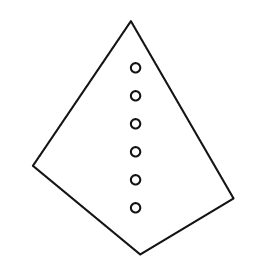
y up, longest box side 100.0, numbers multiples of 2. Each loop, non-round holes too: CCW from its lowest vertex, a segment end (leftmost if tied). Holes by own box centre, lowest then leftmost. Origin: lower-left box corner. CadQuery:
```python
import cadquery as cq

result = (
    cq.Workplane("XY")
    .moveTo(46.0, 0.0)
    .lineTo(86.0, 24.0)
    .lineTo(42.0, 100.0)
    .lineTo(0.0, 38.0)
    .close()
    .moveTo(44.0, 20.0)
    .circle(2.0)
    .moveTo(44.0, 32.0)
    .circle(2.0)
    .moveTo(44.0, 44.0)
    .circle(2.0)
    .moveTo(44.0, 56.0)
    .circle(2.0)
    .moveTo(44.0, 68.0)
    .circle(2.0)
    .moveTo(44.0, 80.0)
    .circle(2.0)
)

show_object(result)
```